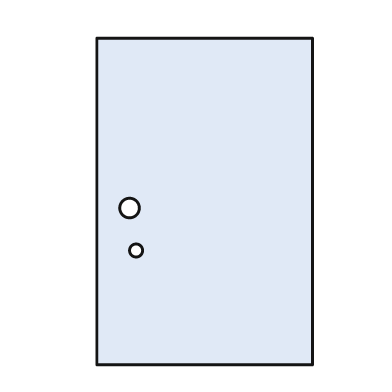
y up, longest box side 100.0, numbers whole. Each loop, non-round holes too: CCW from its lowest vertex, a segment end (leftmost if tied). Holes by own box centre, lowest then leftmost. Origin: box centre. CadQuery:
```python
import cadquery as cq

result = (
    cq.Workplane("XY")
    .moveTo(-33.0, -50.0)
    .lineTo(33.0, -50.0)
    .lineTo(33.0, 50.0)
    .lineTo(-33.0, 50.0)
    .close()
    .moveTo(-21.0, -15.0)
    .circle(2.0)
    .moveTo(-23.0, -2.0)
    .circle(3.0)
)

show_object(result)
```